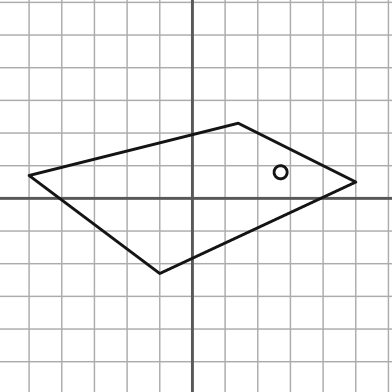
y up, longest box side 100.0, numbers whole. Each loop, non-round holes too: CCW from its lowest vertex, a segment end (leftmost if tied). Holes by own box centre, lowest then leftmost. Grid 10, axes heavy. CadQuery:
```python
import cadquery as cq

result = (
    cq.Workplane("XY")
    .moveTo(-10.0, -23.0)
    .lineTo(50.0, 5.0)
    .lineTo(14.0, 23.0)
    .lineTo(-50.0, 7.0)
    .close()
    .moveTo(27.0, 8.0)
    .circle(2.0)
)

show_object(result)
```